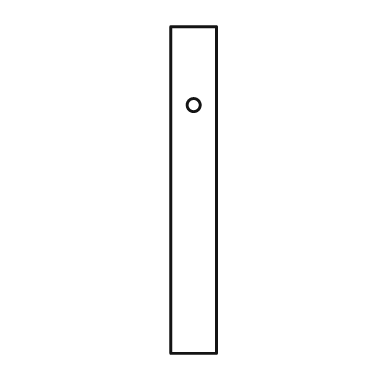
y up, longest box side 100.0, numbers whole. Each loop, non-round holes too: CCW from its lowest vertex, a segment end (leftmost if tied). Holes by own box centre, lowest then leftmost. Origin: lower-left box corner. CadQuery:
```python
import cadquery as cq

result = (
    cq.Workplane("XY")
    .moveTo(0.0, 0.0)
    .lineTo(14.0, 0.0)
    .lineTo(14.0, 100.0)
    .lineTo(0.0, 100.0)
    .close()
    .moveTo(7.0, 76.0)
    .circle(2.0)
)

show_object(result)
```